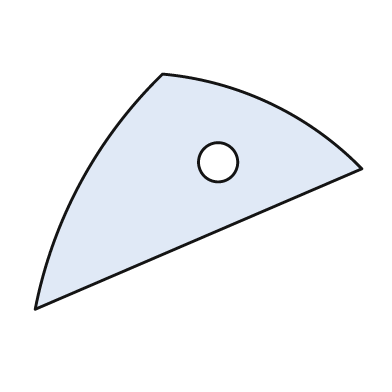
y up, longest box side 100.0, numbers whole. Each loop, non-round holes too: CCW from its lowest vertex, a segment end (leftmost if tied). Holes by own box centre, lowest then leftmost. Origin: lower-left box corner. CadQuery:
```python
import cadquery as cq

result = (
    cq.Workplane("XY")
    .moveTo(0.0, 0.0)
    .lineTo(100.0, 43.0)
    .threePointArc((72.0, 63.0), (39.0, 72.0))
    .threePointArc((14.0, 39.0), (0.0, 0.0))
    .close()
    .moveTo(56.0, 45.0)
    .circle(6.0)
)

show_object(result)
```